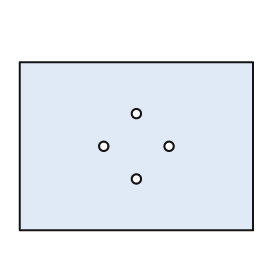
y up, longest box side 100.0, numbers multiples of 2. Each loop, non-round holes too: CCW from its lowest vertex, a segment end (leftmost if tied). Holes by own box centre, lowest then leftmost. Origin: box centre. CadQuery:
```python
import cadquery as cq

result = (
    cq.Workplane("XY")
    .moveTo(-50.0, -36.0)
    .lineTo(50.0, -36.0)
    .lineTo(50.0, 36.0)
    .lineTo(-50.0, 36.0)
    .close()
    .moveTo(0.0, -14.0)
    .circle(2.0)
    .moveTo(-14.0, 0.0)
    .circle(2.0)
    .moveTo(14.0, 0.0)
    .circle(2.0)
    .moveTo(0.0, 14.0)
    .circle(2.0)
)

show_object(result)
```